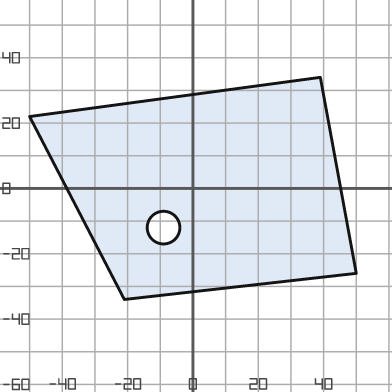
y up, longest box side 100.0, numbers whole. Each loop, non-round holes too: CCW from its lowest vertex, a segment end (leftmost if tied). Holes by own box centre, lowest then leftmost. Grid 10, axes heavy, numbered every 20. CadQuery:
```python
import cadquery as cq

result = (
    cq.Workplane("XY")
    .moveTo(-21.0, -34.0)
    .lineTo(50.0, -26.0)
    .lineTo(39.0, 34.0)
    .lineTo(-50.0, 22.0)
    .close()
    .moveTo(-9.0, -12.0)
    .circle(5.0)
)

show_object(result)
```